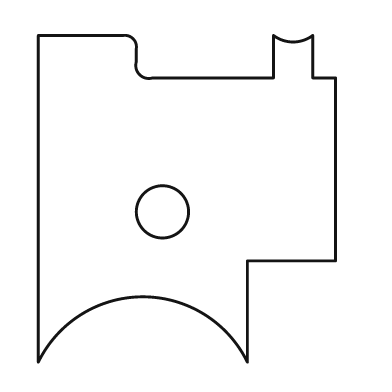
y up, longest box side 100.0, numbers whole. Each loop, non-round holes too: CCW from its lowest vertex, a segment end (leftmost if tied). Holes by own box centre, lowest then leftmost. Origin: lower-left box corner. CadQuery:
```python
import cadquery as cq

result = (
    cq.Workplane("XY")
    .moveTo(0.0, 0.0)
    .threePointArc((32.0, 20.0), (64.0, 0.0))
    .lineTo(64.0, 31.0)
    .lineTo(91.0, 31.0)
    .lineTo(91.0, 87.0)
    .lineTo(84.0, 87.0)
    .lineTo(84.0, 100.0)
    .threePointArc((78.0, 98.0), (72.0, 100.0))
    .lineTo(72.0, 87.0)
    .lineTo(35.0, 87.0)
    .threePointArc((31.0, 88.0), (30.0, 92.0))
    .lineTo(30.0, 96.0)
    .threePointArc((29.0, 99.0), (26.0, 100.0))
    .lineTo(0.0, 100.0)
    .close()
    .moveTo(38.0, 46.0)
    .circle(8.0)
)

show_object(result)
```